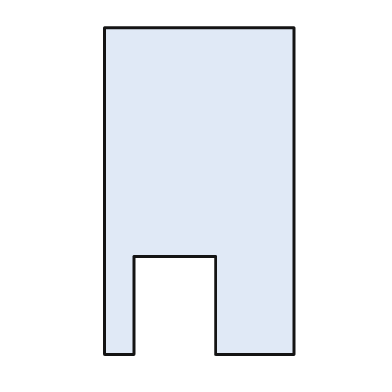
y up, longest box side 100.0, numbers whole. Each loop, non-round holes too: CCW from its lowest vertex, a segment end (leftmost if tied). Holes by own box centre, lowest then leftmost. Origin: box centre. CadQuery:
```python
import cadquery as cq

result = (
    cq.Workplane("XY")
    .moveTo(-29.0, -50.0)
    .lineTo(-20.0, -50.0)
    .lineTo(-20.0, -20.0)
    .lineTo(5.0, -20.0)
    .lineTo(5.0, -50.0)
    .lineTo(29.0, -50.0)
    .lineTo(29.0, 50.0)
    .lineTo(-29.0, 50.0)
    .close()
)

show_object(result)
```